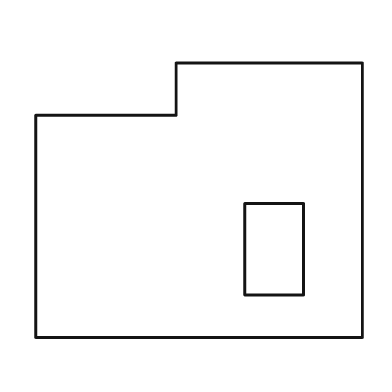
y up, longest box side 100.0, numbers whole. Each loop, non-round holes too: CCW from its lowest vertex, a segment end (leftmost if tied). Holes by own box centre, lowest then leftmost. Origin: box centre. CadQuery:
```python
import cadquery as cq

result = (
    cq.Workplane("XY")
    .moveTo(-50.0, -42.0)
    .lineTo(50.0, -42.0)
    .lineTo(50.0, 42.0)
    .lineTo(-7.0, 42.0)
    .lineTo(-7.0, 26.0)
    .lineTo(-50.0, 26.0)
    .close()
    .moveTo(14.0, -29.0)
    .lineTo(32.0, -29.0)
    .lineTo(32.0, -1.0)
    .lineTo(14.0, -1.0)
    .close()
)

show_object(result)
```